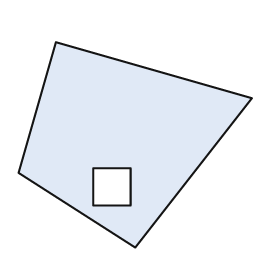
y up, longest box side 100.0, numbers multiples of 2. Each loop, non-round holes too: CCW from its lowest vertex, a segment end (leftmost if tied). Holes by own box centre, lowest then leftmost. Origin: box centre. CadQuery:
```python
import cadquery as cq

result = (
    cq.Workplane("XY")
    .moveTo(0.0, -44.0)
    .lineTo(50.0, 20.0)
    .lineTo(-34.0, 44.0)
    .lineTo(-50.0, -12.0)
    .close()
    .moveTo(-18.0, -26.0)
    .lineTo(-2.0, -26.0)
    .lineTo(-2.0, -10.0)
    .lineTo(-18.0, -10.0)
    .close()
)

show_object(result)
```